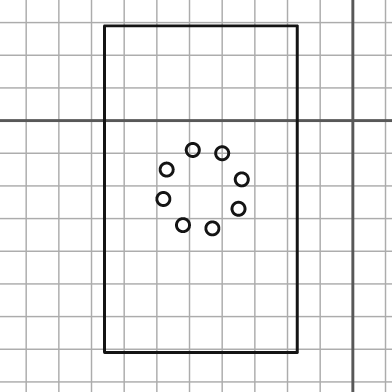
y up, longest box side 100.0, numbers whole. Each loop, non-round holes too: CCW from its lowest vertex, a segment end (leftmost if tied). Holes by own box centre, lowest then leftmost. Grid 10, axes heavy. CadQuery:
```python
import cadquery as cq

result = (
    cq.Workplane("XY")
    .moveTo(-76.0, -71.0)
    .lineTo(-17.0, -71.0)
    .lineTo(-17.0, 29.0)
    .lineTo(-76.0, 29.0)
    .close()
    .moveTo(-43.0, -33.0)
    .circle(2.0)
    .moveTo(-52.0, -32.0)
    .circle(2.0)
    .moveTo(-35.0, -27.0)
    .circle(2.0)
    .moveTo(-58.0, -24.0)
    .circle(2.0)
    .moveTo(-34.0, -18.0)
    .circle(2.0)
    .moveTo(-57.0, -15.0)
    .circle(2.0)
    .moveTo(-40.0, -10.0)
    .circle(2.0)
    .moveTo(-49.0, -9.0)
    .circle(2.0)
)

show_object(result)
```